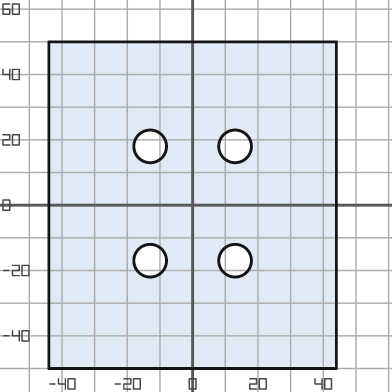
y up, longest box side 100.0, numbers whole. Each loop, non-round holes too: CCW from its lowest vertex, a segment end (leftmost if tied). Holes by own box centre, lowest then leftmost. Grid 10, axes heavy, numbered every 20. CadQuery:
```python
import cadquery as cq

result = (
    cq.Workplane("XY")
    .moveTo(-44.0, -50.0)
    .lineTo(44.0, -50.0)
    .lineTo(44.0, 50.0)
    .lineTo(-44.0, 50.0)
    .close()
    .moveTo(-13.0, -17.0)
    .circle(5.0)
    .moveTo(13.0, -17.0)
    .circle(5.0)
    .moveTo(-13.0, 18.0)
    .circle(5.0)
    .moveTo(13.0, 18.0)
    .circle(5.0)
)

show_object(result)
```